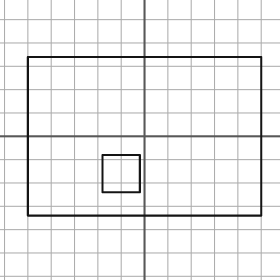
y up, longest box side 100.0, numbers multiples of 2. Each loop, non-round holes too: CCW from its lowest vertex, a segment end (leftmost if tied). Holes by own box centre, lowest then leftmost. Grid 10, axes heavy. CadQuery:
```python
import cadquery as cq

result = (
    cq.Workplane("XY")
    .moveTo(-50.0, -34.0)
    .lineTo(50.0, -34.0)
    .lineTo(50.0, 34.0)
    .lineTo(-50.0, 34.0)
    .close()
    .moveTo(-18.0, -24.0)
    .lineTo(-2.0, -24.0)
    .lineTo(-2.0, -8.0)
    .lineTo(-18.0, -8.0)
    .close()
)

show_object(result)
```